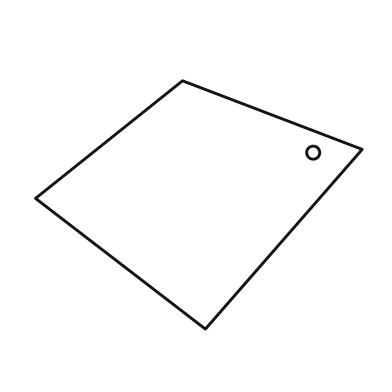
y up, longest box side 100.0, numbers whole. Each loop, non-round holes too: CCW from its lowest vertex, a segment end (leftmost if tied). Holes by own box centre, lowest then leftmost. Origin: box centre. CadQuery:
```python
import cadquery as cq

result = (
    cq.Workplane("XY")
    .moveTo(2.0, -38.0)
    .lineTo(50.0, 17.0)
    .lineTo(-5.0, 38.0)
    .lineTo(-50.0, 2.0)
    .close()
    .moveTo(35.0, 16.0)
    .circle(2.0)
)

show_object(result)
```